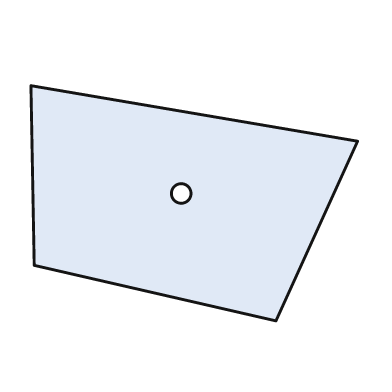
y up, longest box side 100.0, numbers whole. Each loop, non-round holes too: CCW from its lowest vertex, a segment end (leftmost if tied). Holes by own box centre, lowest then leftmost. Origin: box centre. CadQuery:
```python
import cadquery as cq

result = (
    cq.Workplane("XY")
    .moveTo(25.0, -36.0)
    .lineTo(50.0, 19.0)
    .lineTo(-50.0, 36.0)
    .lineTo(-49.0, -19.0)
    .close()
    .moveTo(-4.0, 3.0)
    .circle(3.0)
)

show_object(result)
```